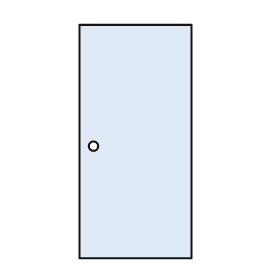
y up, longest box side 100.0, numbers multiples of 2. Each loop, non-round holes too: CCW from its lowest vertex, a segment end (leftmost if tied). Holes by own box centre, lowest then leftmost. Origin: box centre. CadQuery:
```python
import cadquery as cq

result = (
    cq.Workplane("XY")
    .moveTo(-24.0, -50.0)
    .lineTo(24.0, -50.0)
    .lineTo(24.0, 50.0)
    .lineTo(-24.0, 50.0)
    .close()
    .moveTo(-18.0, -2.0)
    .circle(2.0)
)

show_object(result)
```